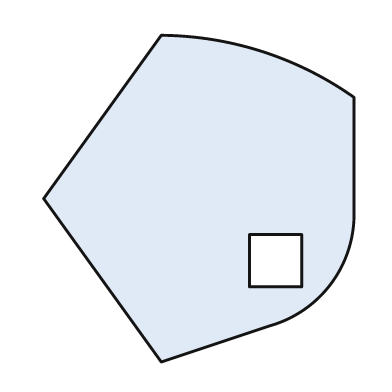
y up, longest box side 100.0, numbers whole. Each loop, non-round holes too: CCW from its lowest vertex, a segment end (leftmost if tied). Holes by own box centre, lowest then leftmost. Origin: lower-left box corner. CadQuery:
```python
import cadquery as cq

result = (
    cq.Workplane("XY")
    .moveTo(36.0, 0.0)
    .lineTo(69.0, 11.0)
    .threePointArc((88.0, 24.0), (95.0, 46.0))
    .lineTo(95.0, 81.0)
    .threePointArc((67.0, 95.0), (36.0, 100.0))
    .lineTo(0.0, 50.0)
    .close()
    .moveTo(63.0, 23.0)
    .lineTo(79.0, 23.0)
    .lineTo(79.0, 39.0)
    .lineTo(63.0, 39.0)
    .close()
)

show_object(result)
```